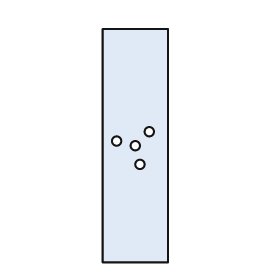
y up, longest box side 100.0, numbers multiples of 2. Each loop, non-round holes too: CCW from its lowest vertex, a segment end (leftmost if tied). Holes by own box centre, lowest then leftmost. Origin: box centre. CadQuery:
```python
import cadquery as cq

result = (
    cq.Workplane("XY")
    .moveTo(-14.0, -50.0)
    .lineTo(14.0, -50.0)
    .lineTo(14.0, 50.0)
    .lineTo(-14.0, 50.0)
    .close()
    .moveTo(2.0, -8.0)
    .circle(2.0)
    .moveTo(0.0, 0.0)
    .circle(2.0)
    .moveTo(-8.0, 2.0)
    .circle(2.0)
    .moveTo(6.0, 6.0)
    .circle(2.0)
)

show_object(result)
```